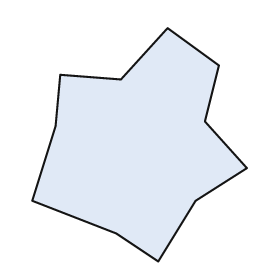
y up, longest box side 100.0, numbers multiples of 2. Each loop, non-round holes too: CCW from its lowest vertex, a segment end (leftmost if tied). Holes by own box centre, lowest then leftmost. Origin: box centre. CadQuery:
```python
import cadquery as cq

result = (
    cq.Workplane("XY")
    .moveTo(8.0, -50.0)
    .lineTo(24.0, -24.0)
    .lineTo(46.0, -10.0)
    .lineTo(28.0, 10.0)
    .lineTo(34.0, 34.0)
    .lineTo(12.0, 50.0)
    .lineTo(-8.0, 28.0)
    .lineTo(-34.0, 30.0)
    .lineTo(-36.0, 8.0)
    .lineTo(-46.0, -24.0)
    .lineTo(-10.0, -38.0)
    .close()
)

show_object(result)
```